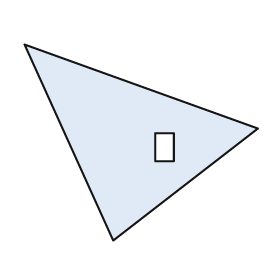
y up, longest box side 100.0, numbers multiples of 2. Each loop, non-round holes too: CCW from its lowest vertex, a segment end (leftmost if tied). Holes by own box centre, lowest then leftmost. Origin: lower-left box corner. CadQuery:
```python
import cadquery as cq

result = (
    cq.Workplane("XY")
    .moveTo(38.0, 0.0)
    .lineTo(100.0, 48.0)
    .lineTo(0.0, 84.0)
    .close()
    .moveTo(56.0, 34.0)
    .lineTo(64.0, 34.0)
    .lineTo(64.0, 46.0)
    .lineTo(56.0, 46.0)
    .close()
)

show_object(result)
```